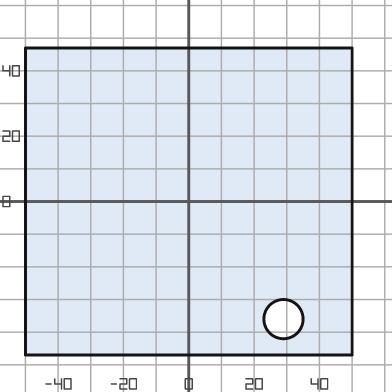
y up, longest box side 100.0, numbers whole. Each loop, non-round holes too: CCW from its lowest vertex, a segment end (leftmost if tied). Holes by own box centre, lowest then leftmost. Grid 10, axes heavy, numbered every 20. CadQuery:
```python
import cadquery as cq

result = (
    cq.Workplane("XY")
    .moveTo(-50.0, -47.0)
    .lineTo(50.0, -47.0)
    .lineTo(50.0, 47.0)
    .lineTo(-50.0, 47.0)
    .close()
    .moveTo(29.0, -36.0)
    .circle(6.0)
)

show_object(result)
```